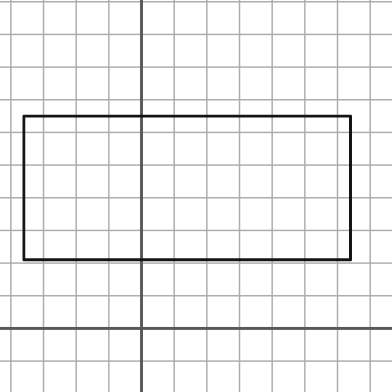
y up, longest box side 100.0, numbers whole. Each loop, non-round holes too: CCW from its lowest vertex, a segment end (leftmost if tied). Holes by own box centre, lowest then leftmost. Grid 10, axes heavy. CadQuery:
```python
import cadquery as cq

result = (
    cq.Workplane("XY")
    .moveTo(-36.0, 21.0)
    .lineTo(64.0, 21.0)
    .lineTo(64.0, 65.0)
    .lineTo(-36.0, 65.0)
    .close()
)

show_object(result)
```